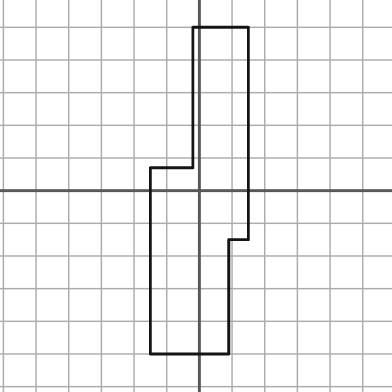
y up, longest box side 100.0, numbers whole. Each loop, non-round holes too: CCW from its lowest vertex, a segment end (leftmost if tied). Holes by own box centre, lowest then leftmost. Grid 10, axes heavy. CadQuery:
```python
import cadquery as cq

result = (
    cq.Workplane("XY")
    .moveTo(-15.0, -50.0)
    .lineTo(9.0, -50.0)
    .lineTo(9.0, -15.0)
    .lineTo(15.0, -15.0)
    .lineTo(15.0, 50.0)
    .lineTo(-2.0, 50.0)
    .lineTo(-2.0, 7.0)
    .lineTo(-15.0, 7.0)
    .close()
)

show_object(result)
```